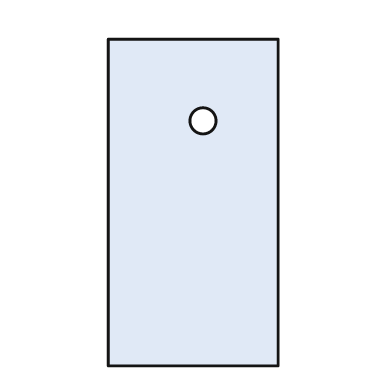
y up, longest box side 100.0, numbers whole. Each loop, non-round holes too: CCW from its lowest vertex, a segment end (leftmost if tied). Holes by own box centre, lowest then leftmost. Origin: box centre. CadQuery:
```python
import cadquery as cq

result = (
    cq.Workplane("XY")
    .moveTo(-26.0, -50.0)
    .lineTo(26.0, -50.0)
    .lineTo(26.0, 50.0)
    .lineTo(-26.0, 50.0)
    .close()
    .moveTo(3.0, 25.0)
    .circle(4.0)
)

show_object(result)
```